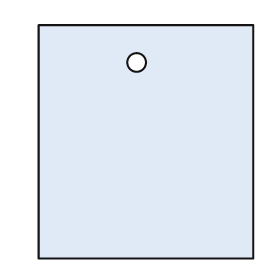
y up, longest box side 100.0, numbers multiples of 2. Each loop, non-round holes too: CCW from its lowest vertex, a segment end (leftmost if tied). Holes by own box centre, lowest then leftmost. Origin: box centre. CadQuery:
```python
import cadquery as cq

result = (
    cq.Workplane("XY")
    .moveTo(-46.0, -50.0)
    .lineTo(46.0, -50.0)
    .lineTo(46.0, 50.0)
    .lineTo(-46.0, 50.0)
    .close()
    .moveTo(-4.0, 34.0)
    .circle(4.0)
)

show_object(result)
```